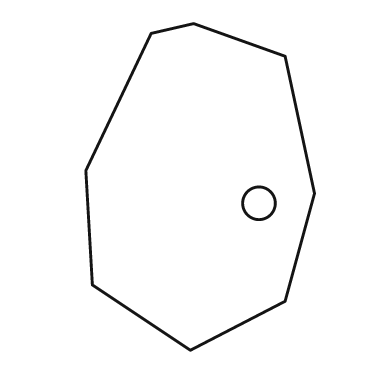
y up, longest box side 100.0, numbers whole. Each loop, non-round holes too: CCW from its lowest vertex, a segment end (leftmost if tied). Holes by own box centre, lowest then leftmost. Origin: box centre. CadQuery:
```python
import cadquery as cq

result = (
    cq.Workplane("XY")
    .moveTo(-3.0, -50.0)
    .lineTo(26.0, -35.0)
    .lineTo(35.0, -2.0)
    .lineTo(26.0, 40.0)
    .lineTo(-2.0, 50.0)
    .lineTo(-15.0, 47.0)
    .lineTo(-35.0, 5.0)
    .lineTo(-33.0, -30.0)
    .close()
    .moveTo(18.0, -5.0)
    .circle(5.0)
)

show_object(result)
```